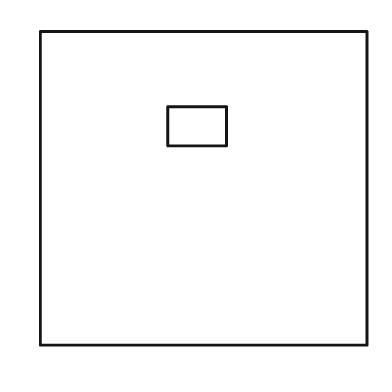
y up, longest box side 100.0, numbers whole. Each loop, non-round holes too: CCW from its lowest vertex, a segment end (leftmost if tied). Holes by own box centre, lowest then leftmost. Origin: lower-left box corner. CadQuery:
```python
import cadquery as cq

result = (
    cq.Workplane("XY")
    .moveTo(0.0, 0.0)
    .lineTo(100.0, 0.0)
    .lineTo(100.0, 96.0)
    .lineTo(0.0, 96.0)
    .close()
    .moveTo(39.0, 61.0)
    .lineTo(57.0, 61.0)
    .lineTo(57.0, 73.0)
    .lineTo(39.0, 73.0)
    .close()
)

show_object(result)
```